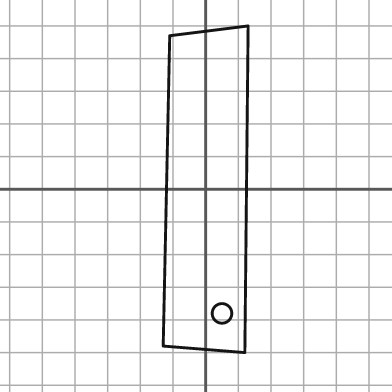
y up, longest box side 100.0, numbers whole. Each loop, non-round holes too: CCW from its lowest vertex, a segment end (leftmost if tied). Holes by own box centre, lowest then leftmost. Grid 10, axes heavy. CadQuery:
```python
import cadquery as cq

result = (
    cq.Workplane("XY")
    .moveTo(12.0, -50.0)
    .lineTo(13.0, 50.0)
    .lineTo(-11.0, 47.0)
    .lineTo(-13.0, -48.0)
    .close()
    .moveTo(5.0, -38.0)
    .circle(3.0)
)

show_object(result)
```